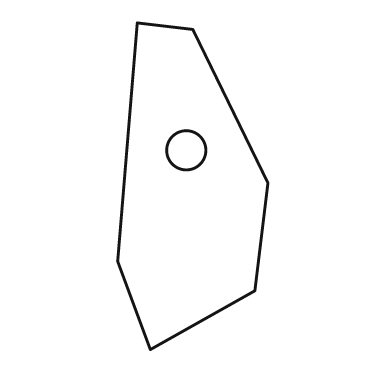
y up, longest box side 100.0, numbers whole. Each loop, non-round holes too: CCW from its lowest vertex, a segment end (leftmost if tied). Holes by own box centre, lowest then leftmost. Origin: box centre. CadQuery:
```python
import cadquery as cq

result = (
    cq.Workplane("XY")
    .moveTo(-13.0, -50.0)
    .lineTo(19.0, -32.0)
    .lineTo(23.0, 1.0)
    .lineTo(0.0, 48.0)
    .lineTo(-17.0, 50.0)
    .lineTo(-23.0, -23.0)
    .close()
    .moveTo(-2.0, 11.0)
    .circle(6.0)
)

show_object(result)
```